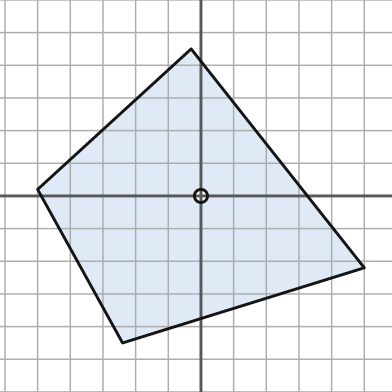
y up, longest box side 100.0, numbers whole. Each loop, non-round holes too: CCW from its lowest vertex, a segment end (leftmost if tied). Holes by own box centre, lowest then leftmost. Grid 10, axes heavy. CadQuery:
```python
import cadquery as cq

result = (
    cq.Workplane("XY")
    .moveTo(-24.0, -45.0)
    .lineTo(50.0, -22.0)
    .lineTo(-3.0, 45.0)
    .lineTo(-50.0, 2.0)
    .close()
    .moveTo(0.0, 0.0)
    .circle(2.0)
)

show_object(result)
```